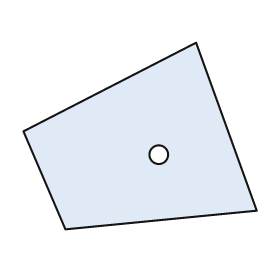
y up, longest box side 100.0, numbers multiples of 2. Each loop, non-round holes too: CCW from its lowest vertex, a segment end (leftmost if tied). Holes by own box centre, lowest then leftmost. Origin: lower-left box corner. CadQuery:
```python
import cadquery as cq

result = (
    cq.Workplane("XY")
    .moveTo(18.0, 0.0)
    .lineTo(100.0, 8.0)
    .lineTo(74.0, 80.0)
    .lineTo(0.0, 42.0)
    .close()
    .moveTo(58.0, 32.0)
    .circle(4.0)
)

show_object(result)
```